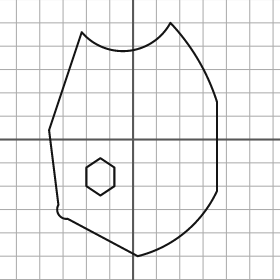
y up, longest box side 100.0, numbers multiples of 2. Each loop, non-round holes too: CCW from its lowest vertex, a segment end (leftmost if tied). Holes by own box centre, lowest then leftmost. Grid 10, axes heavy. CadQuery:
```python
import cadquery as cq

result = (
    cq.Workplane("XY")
    .moveTo(2.0, -50.0)
    .threePointArc((22.0, -40.0), (36.0, -22.0))
    .lineTo(36.0, 16.0)
    .threePointArc((28.0, 34.0), (16.0, 50.0))
    .threePointArc((-2.0, 38.0), (-22.0, 46.0))
    .lineTo(-36.0, 4.0)
    .lineTo(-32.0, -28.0)
    .threePointArc((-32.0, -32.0), (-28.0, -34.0))
    .close()
    .moveTo(-14.0, -24.0)
    .lineTo(-8.0, -20.0)
    .lineTo(-8.0, -12.0)
    .lineTo(-14.0, -8.0)
    .lineTo(-20.0, -12.0)
    .lineTo(-20.0, -20.0)
    .close()
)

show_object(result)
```